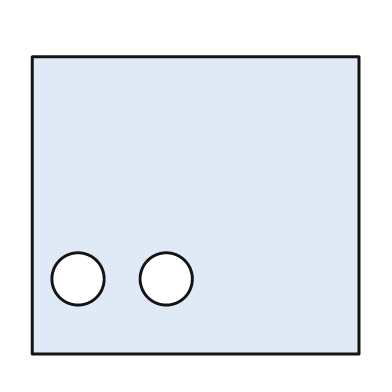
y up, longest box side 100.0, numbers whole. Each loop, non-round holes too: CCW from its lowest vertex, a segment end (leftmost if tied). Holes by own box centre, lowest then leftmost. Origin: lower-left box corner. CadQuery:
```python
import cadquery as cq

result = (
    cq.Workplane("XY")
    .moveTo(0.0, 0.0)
    .lineTo(100.0, 0.0)
    .lineTo(100.0, 91.0)
    .lineTo(0.0, 91.0)
    .close()
    .moveTo(14.0, 23.0)
    .circle(8.0)
    .moveTo(41.0, 23.0)
    .circle(8.0)
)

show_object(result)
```